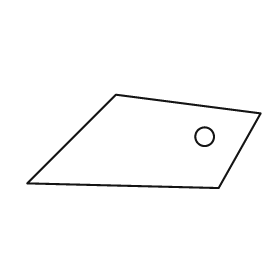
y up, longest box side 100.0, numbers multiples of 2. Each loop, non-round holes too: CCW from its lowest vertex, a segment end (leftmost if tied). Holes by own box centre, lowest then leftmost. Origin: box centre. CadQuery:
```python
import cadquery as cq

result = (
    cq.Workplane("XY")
    .moveTo(32.0, -20.0)
    .lineTo(50.0, 12.0)
    .lineTo(-12.0, 20.0)
    .lineTo(-50.0, -18.0)
    .close()
    .moveTo(26.0, 2.0)
    .circle(4.0)
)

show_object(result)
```